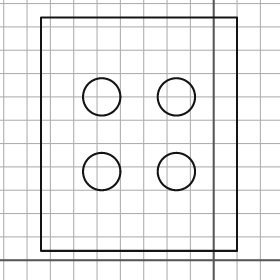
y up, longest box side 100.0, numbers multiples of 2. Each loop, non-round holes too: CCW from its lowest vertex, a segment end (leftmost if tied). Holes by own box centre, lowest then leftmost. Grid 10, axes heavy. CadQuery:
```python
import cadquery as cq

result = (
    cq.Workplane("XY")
    .moveTo(-74.0, 4.0)
    .lineTo(10.0, 4.0)
    .lineTo(10.0, 104.0)
    .lineTo(-74.0, 104.0)
    .close()
    .moveTo(-48.0, 38.0)
    .circle(8.0)
    .moveTo(-16.0, 38.0)
    .circle(8.0)
    .moveTo(-48.0, 70.0)
    .circle(8.0)
    .moveTo(-16.0, 70.0)
    .circle(8.0)
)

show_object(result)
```